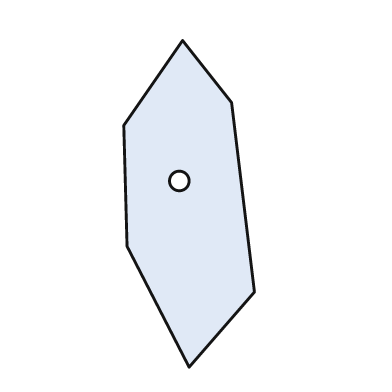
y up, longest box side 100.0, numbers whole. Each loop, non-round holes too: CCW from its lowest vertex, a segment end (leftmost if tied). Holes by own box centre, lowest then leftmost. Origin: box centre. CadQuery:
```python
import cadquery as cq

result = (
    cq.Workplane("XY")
    .moveTo(0.0, -50.0)
    .lineTo(20.0, -27.0)
    .lineTo(13.0, 31.0)
    .lineTo(-2.0, 50.0)
    .lineTo(-20.0, 24.0)
    .lineTo(-19.0, -13.0)
    .close()
    .moveTo(-3.0, 7.0)
    .circle(3.0)
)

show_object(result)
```